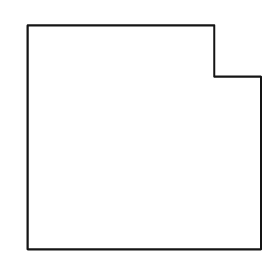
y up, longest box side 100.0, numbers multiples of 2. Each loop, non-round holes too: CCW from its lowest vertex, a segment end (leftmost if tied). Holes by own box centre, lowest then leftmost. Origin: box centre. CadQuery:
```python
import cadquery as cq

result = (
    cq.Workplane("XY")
    .moveTo(-50.0, -48.0)
    .lineTo(50.0, -48.0)
    .lineTo(50.0, 26.0)
    .lineTo(30.0, 26.0)
    .lineTo(30.0, 48.0)
    .lineTo(-50.0, 48.0)
    .close()
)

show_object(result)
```